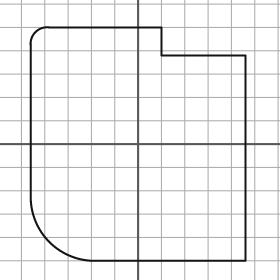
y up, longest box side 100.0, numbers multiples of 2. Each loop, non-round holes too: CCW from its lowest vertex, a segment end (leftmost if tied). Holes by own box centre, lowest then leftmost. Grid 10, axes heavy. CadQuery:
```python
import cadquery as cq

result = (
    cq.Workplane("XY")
    .moveTo(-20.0, -50.0)
    .lineTo(46.0, -50.0)
    .lineTo(46.0, 38.0)
    .lineTo(10.0, 38.0)
    .lineTo(10.0, 50.0)
    .lineTo(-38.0, 50.0)
    .threePointArc((-44.0, 48.0), (-46.0, 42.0))
    .lineTo(-46.0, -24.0)
    .threePointArc((-38.0, -42.0), (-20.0, -50.0))
    .close()
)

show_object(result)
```